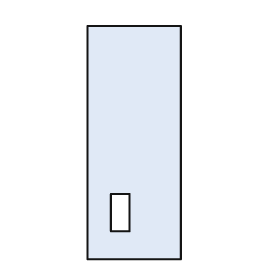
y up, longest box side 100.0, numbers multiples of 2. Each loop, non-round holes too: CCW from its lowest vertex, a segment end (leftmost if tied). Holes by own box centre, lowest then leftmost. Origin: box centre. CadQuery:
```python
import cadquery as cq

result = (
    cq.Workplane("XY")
    .moveTo(-20.0, -50.0)
    .lineTo(20.0, -50.0)
    .lineTo(20.0, 50.0)
    .lineTo(-20.0, 50.0)
    .close()
    .moveTo(-10.0, -38.0)
    .lineTo(-2.0, -38.0)
    .lineTo(-2.0, -22.0)
    .lineTo(-10.0, -22.0)
    .close()
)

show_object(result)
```